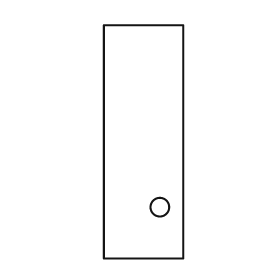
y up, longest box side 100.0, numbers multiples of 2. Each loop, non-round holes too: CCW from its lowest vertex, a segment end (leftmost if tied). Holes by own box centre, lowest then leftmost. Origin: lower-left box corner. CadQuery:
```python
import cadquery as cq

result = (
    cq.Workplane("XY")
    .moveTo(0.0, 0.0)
    .lineTo(34.0, 0.0)
    .lineTo(34.0, 100.0)
    .lineTo(0.0, 100.0)
    .close()
    .moveTo(24.0, 22.0)
    .circle(4.0)
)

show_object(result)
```